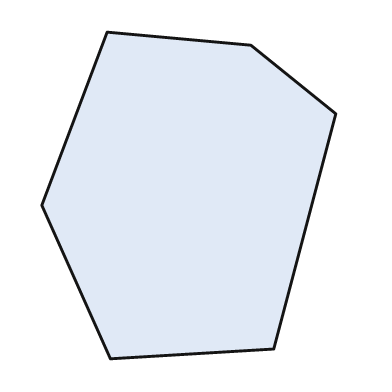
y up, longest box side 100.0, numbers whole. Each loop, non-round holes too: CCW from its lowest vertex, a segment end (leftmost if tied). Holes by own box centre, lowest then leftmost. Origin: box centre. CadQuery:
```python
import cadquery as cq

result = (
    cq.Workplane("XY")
    .moveTo(-24.0, -50.0)
    .lineTo(26.0, -47.0)
    .lineTo(45.0, 25.0)
    .lineTo(19.0, 46.0)
    .lineTo(-25.0, 50.0)
    .lineTo(-45.0, -3.0)
    .close()
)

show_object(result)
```